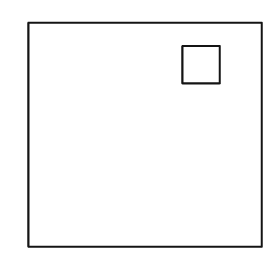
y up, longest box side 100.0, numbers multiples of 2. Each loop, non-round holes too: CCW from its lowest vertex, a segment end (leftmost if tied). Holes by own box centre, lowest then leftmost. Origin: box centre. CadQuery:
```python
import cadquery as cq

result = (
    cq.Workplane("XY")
    .moveTo(-50.0, -48.0)
    .lineTo(50.0, -48.0)
    .lineTo(50.0, 48.0)
    .lineTo(-50.0, 48.0)
    .close()
    .moveTo(16.0, 22.0)
    .lineTo(32.0, 22.0)
    .lineTo(32.0, 38.0)
    .lineTo(16.0, 38.0)
    .close()
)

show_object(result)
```